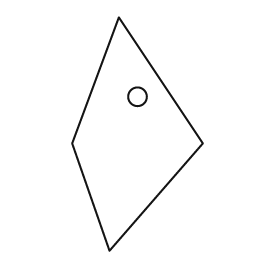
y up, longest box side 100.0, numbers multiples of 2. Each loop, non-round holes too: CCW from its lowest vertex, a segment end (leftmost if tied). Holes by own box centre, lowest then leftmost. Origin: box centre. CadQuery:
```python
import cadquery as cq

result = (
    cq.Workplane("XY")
    .moveTo(-12.0, -50.0)
    .lineTo(28.0, -4.0)
    .lineTo(-8.0, 50.0)
    .lineTo(-28.0, -4.0)
    .close()
    .moveTo(0.0, 16.0)
    .circle(4.0)
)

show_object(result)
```